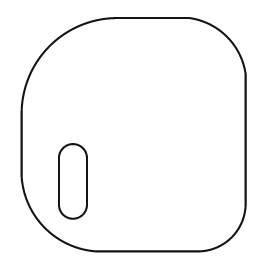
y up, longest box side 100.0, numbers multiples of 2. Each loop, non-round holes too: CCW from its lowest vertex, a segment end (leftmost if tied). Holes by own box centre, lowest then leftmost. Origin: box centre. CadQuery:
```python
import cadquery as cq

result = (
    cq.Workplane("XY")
    .moveTo(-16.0, -50.0)
    .lineTo(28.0, -50.0)
    .threePointArc((42.0, -44.0), (48.0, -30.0))
    .lineTo(48.0, 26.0)
    .threePointArc((40.0, 42.0), (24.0, 50.0))
    .lineTo(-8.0, 50.0)
    .threePointArc((-36.0, 38.0), (-48.0, 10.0))
    .lineTo(-48.0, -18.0)
    .threePointArc((-38.0, -40.0), (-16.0, -50.0))
    .close()
    .moveTo(-32.0, -30.0)
    .threePointArc((-26.0, -36.0), (-20.0, -30.0))
    .lineTo(-20.0, -10.0)
    .threePointArc((-26.0, -4.0), (-32.0, -10.0))
    .close()
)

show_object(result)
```